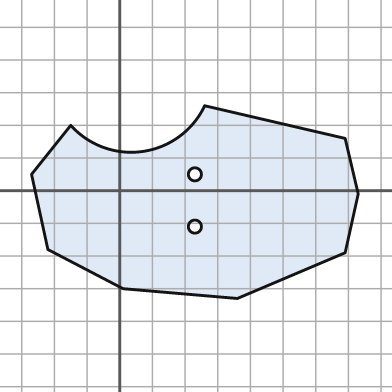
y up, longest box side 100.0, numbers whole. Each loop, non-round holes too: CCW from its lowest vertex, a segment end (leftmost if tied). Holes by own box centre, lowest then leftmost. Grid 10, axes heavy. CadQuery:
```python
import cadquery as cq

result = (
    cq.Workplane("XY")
    .moveTo(36.0, -33.0)
    .lineTo(69.0, -19.0)
    .lineTo(73.0, -1.0)
    .lineTo(69.0, 16.0)
    .lineTo(26.0, 26.0)
    .threePointArc((7.0, 12.0), (-15.0, 20.0))
    .lineTo(-27.0, 5.0)
    .lineTo(-22.0, -18.0)
    .lineTo(1.0, -30.0)
    .close()
    .moveTo(23.0, -11.0)
    .circle(2.0)
    .moveTo(23.0, 5.0)
    .circle(2.0)
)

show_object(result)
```